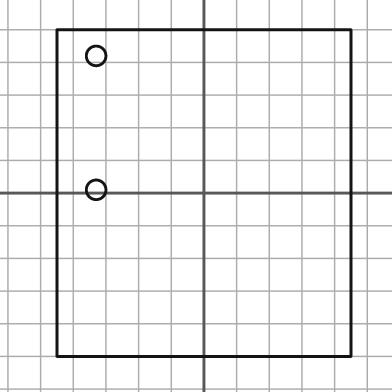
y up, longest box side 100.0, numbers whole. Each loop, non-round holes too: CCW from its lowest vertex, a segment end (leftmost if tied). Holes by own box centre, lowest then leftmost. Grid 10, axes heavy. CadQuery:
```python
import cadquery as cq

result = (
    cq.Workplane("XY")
    .moveTo(-45.0, -50.0)
    .lineTo(45.0, -50.0)
    .lineTo(45.0, 50.0)
    .lineTo(-45.0, 50.0)
    .close()
    .moveTo(-33.0, 1.0)
    .circle(3.0)
    .moveTo(-33.0, 42.0)
    .circle(3.0)
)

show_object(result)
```